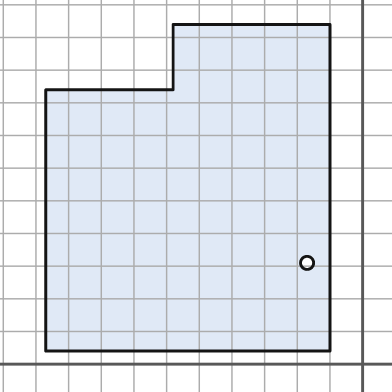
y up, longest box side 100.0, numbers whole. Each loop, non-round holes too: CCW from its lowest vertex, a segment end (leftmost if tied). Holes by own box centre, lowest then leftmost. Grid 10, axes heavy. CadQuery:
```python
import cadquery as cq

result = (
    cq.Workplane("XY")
    .moveTo(-97.0, 4.0)
    .lineTo(-10.0, 4.0)
    .lineTo(-10.0, 104.0)
    .lineTo(-58.0, 104.0)
    .lineTo(-58.0, 84.0)
    .lineTo(-97.0, 84.0)
    .close()
    .moveTo(-17.0, 31.0)
    .circle(2.0)
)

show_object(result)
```